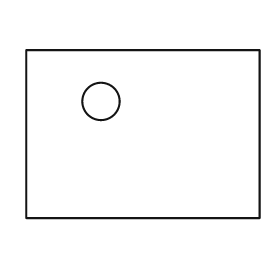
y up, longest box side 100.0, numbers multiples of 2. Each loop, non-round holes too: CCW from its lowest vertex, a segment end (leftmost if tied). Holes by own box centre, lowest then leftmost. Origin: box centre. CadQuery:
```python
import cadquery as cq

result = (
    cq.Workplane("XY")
    .moveTo(-50.0, -36.0)
    .lineTo(50.0, -36.0)
    .lineTo(50.0, 36.0)
    .lineTo(-50.0, 36.0)
    .close()
    .moveTo(-18.0, 14.0)
    .circle(8.0)
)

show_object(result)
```